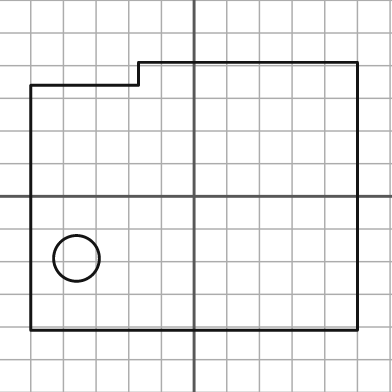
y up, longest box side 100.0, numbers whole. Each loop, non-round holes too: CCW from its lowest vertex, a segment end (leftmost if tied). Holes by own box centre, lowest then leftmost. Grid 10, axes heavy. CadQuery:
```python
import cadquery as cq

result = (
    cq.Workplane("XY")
    .moveTo(-50.0, -41.0)
    .lineTo(50.0, -41.0)
    .lineTo(50.0, 41.0)
    .lineTo(-17.0, 41.0)
    .lineTo(-17.0, 34.0)
    .lineTo(-50.0, 34.0)
    .close()
    .moveTo(-36.0, -19.0)
    .circle(7.0)
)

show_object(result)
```